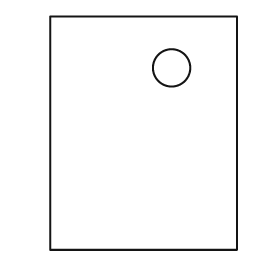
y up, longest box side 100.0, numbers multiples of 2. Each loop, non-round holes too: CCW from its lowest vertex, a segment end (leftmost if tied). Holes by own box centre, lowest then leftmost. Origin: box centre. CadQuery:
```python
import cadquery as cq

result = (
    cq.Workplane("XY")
    .moveTo(-40.0, -50.0)
    .lineTo(40.0, -50.0)
    .lineTo(40.0, 50.0)
    .lineTo(-40.0, 50.0)
    .close()
    .moveTo(12.0, 28.0)
    .circle(8.0)
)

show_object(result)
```